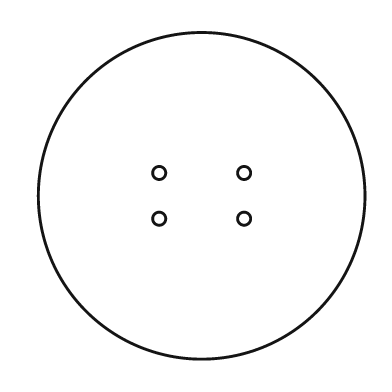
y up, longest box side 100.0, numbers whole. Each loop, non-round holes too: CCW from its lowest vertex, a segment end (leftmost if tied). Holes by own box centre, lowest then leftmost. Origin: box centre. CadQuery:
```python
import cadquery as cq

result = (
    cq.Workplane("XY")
    .moveTo(0.0, 0.0)
    .circle(50.0)
    .moveTo(-13.0, -7.0)
    .circle(2.0)
    .moveTo(13.0, -7.0)
    .circle(2.0)
    .moveTo(-13.0, 7.0)
    .circle(2.0)
    .moveTo(13.0, 7.0)
    .circle(2.0)
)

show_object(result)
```